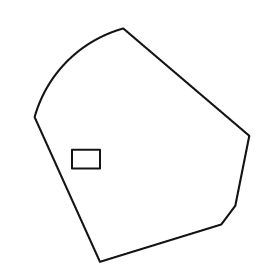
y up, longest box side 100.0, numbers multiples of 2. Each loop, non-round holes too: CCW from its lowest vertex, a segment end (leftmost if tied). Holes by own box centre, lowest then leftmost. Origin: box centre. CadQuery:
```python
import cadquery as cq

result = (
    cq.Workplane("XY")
    .moveTo(-18.0, -50.0)
    .lineTo(34.0, -34.0)
    .lineTo(40.0, -26.0)
    .lineTo(46.0, 4.0)
    .lineTo(-8.0, 50.0)
    .threePointArc((-32.0, 36.0), (-46.0, 12.0))
    .close()
    .moveTo(-30.0, -10.0)
    .lineTo(-18.0, -10.0)
    .lineTo(-18.0, -2.0)
    .lineTo(-30.0, -2.0)
    .close()
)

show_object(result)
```